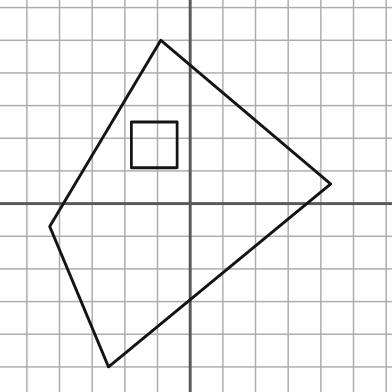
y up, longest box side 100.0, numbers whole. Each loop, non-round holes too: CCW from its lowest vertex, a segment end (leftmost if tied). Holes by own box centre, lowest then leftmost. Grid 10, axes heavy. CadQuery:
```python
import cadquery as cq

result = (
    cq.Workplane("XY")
    .moveTo(-25.0, -50.0)
    .lineTo(43.0, 6.0)
    .lineTo(-9.0, 50.0)
    .lineTo(-43.0, -7.0)
    .close()
    .moveTo(-18.0, 11.0)
    .lineTo(-4.0, 11.0)
    .lineTo(-4.0, 25.0)
    .lineTo(-18.0, 25.0)
    .close()
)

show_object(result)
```